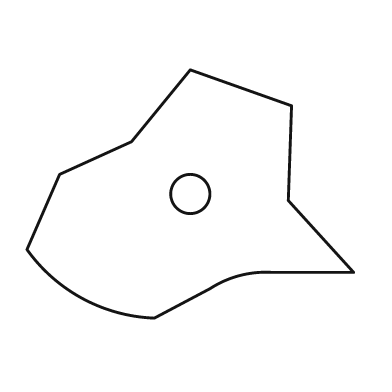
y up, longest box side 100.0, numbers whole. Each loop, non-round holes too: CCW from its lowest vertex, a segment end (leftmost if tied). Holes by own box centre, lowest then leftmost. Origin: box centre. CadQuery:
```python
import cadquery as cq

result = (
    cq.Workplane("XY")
    .moveTo(-11.0, -38.0)
    .lineTo(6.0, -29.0)
    .threePointArc((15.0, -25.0), (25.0, -24.0))
    .lineTo(50.0, -24.0)
    .lineTo(30.0, -2.0)
    .lineTo(31.0, 27.0)
    .lineTo(0.0, 38.0)
    .lineTo(-18.0, 16.0)
    .lineTo(-40.0, 6.0)
    .lineTo(-50.0, -17.0)
    .threePointArc((-33.0, -32.0), (-11.0, -38.0))
    .close()
    .moveTo(0.0, 0.0)
    .circle(6.0)
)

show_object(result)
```